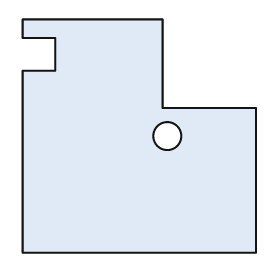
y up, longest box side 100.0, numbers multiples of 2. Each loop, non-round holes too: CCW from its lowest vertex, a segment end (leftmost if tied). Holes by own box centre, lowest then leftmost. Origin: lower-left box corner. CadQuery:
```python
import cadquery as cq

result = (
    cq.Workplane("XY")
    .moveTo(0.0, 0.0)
    .lineTo(100.0, 0.0)
    .lineTo(100.0, 62.0)
    .lineTo(60.0, 62.0)
    .lineTo(60.0, 100.0)
    .lineTo(0.0, 100.0)
    .lineTo(0.0, 92.0)
    .lineTo(14.0, 92.0)
    .lineTo(14.0, 78.0)
    .lineTo(0.0, 78.0)
    .close()
    .moveTo(62.0, 50.0)
    .circle(6.0)
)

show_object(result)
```